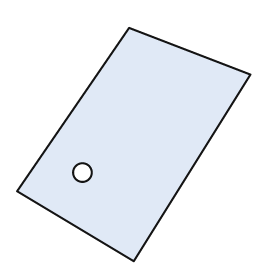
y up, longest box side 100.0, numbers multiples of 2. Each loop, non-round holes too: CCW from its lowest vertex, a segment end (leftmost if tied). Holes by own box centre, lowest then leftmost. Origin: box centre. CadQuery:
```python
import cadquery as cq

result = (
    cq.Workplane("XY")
    .moveTo(0.0, -50.0)
    .lineTo(50.0, 30.0)
    .lineTo(-2.0, 50.0)
    .lineTo(-50.0, -20.0)
    .close()
    .moveTo(-22.0, -12.0)
    .circle(4.0)
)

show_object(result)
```